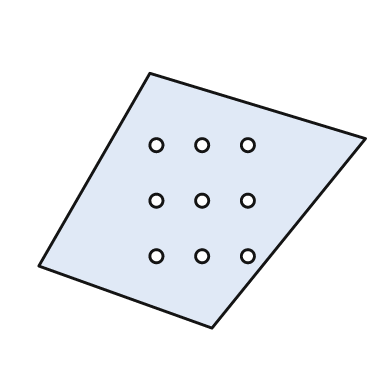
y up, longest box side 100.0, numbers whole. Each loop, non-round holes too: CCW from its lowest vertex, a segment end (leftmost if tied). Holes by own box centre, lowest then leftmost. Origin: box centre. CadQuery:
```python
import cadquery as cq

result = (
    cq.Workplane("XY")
    .moveTo(3.0, -39.0)
    .lineTo(50.0, 19.0)
    .lineTo(-16.0, 39.0)
    .lineTo(-50.0, -20.0)
    .close()
    .moveTo(-14.0, -17.0)
    .circle(2.0)
    .moveTo(0.0, -17.0)
    .circle(2.0)
    .moveTo(14.0, -17.0)
    .circle(2.0)
    .moveTo(-14.0, 0.0)
    .circle(2.0)
    .moveTo(0.0, 0.0)
    .circle(2.0)
    .moveTo(14.0, 0.0)
    .circle(2.0)
    .moveTo(-14.0, 17.0)
    .circle(2.0)
    .moveTo(0.0, 17.0)
    .circle(2.0)
    .moveTo(14.0, 17.0)
    .circle(2.0)
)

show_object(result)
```